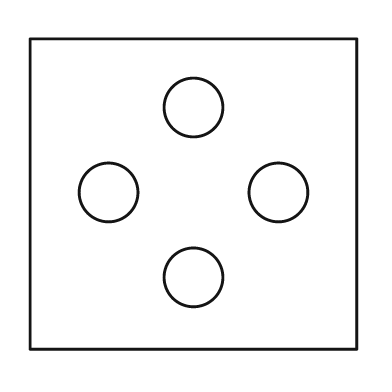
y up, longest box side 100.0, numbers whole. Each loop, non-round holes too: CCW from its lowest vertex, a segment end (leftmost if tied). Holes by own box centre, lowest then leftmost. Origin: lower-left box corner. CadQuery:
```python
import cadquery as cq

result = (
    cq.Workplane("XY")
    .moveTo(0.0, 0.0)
    .lineTo(100.0, 0.0)
    .lineTo(100.0, 95.0)
    .lineTo(0.0, 95.0)
    .close()
    .moveTo(50.0, 22.0)
    .circle(9.0)
    .moveTo(24.0, 48.0)
    .circle(9.0)
    .moveTo(76.0, 48.0)
    .circle(9.0)
    .moveTo(50.0, 74.0)
    .circle(9.0)
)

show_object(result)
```